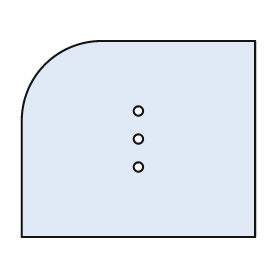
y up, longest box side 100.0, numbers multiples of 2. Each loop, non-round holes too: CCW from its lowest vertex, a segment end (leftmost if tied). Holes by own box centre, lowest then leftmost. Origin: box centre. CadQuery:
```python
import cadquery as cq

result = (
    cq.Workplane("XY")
    .moveTo(-50.0, -42.0)
    .lineTo(50.0, -42.0)
    .lineTo(50.0, 42.0)
    .lineTo(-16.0, 42.0)
    .threePointArc((-40.0, 32.0), (-50.0, 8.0))
    .close()
    .moveTo(0.0, -12.0)
    .circle(2.0)
    .moveTo(0.0, 0.0)
    .circle(2.0)
    .moveTo(0.0, 12.0)
    .circle(2.0)
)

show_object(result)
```